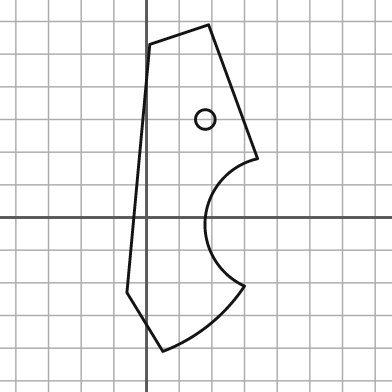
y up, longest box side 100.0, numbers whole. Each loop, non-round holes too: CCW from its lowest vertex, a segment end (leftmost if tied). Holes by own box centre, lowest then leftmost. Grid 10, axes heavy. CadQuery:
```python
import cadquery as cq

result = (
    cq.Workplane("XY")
    .moveTo(5.0, -41.0)
    .threePointArc((19.0, -33.0), (30.0, -21.0))
    .threePointArc((18.0, 0.0), (34.0, 18.0))
    .lineTo(19.0, 59.0)
    .lineTo(1.0, 53.0)
    .lineTo(-6.0, -23.0)
    .close()
    .moveTo(18.0, 30.0)
    .circle(3.0)
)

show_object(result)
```